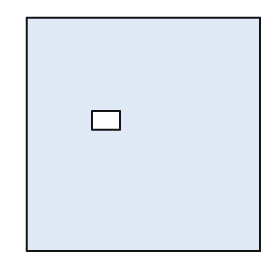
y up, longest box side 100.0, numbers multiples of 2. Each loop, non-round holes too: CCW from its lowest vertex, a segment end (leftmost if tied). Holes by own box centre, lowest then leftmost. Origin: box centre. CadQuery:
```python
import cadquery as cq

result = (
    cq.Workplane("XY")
    .moveTo(-50.0, -50.0)
    .lineTo(50.0, -50.0)
    .lineTo(50.0, 50.0)
    .lineTo(-50.0, 50.0)
    .close()
    .moveTo(-22.0, 2.0)
    .lineTo(-10.0, 2.0)
    .lineTo(-10.0, 10.0)
    .lineTo(-22.0, 10.0)
    .close()
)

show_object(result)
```